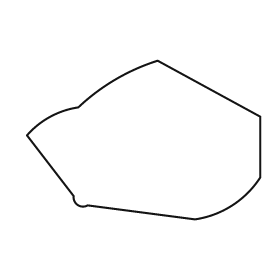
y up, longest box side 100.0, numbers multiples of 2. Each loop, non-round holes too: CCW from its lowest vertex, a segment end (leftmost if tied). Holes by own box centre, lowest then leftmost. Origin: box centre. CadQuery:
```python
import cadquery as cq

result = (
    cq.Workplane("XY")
    .moveTo(22.0, -34.0)
    .threePointArc((38.0, -28.0), (50.0, -16.0))
    .lineTo(50.0, 10.0)
    .lineTo(6.0, 34.0)
    .threePointArc((-12.0, 26.0), (-28.0, 14.0))
    .threePointArc((-40.0, 10.0), (-50.0, 2.0))
    .lineTo(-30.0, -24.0)
    .threePointArc((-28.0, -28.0), (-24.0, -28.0))
    .close()
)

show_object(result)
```